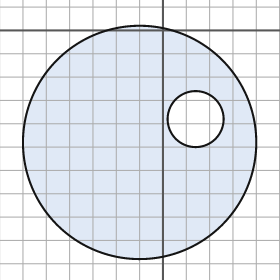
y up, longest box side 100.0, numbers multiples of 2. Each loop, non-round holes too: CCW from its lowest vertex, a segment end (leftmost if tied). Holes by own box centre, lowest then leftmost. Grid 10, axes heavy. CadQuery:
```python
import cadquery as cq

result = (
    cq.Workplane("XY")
    .moveTo(-10.0, -48.0)
    .circle(50.0)
    .moveTo(14.0, -38.0)
    .circle(12.0)
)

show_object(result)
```